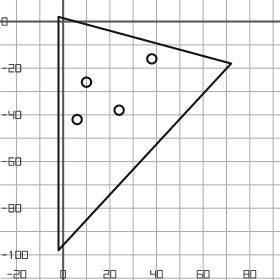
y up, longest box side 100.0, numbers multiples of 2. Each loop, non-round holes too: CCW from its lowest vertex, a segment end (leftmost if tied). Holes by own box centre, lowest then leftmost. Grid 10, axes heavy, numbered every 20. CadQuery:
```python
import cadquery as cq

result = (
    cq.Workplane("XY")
    .moveTo(-2.0, -98.0)
    .lineTo(72.0, -18.0)
    .lineTo(-2.0, 2.0)
    .close()
    .moveTo(6.0, -42.0)
    .circle(2.0)
    .moveTo(24.0, -38.0)
    .circle(2.0)
    .moveTo(10.0, -26.0)
    .circle(2.0)
    .moveTo(38.0, -16.0)
    .circle(2.0)
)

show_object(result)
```